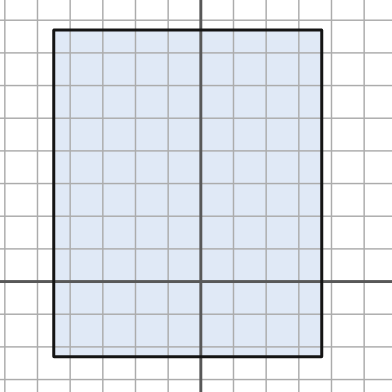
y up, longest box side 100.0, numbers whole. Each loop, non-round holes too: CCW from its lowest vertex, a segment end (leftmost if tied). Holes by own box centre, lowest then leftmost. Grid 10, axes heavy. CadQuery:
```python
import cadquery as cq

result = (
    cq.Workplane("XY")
    .moveTo(-45.0, -23.0)
    .lineTo(37.0, -23.0)
    .lineTo(37.0, 77.0)
    .lineTo(-45.0, 77.0)
    .close()
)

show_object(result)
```